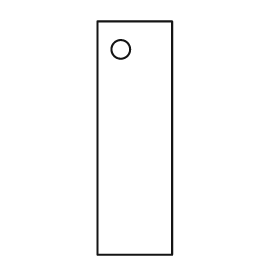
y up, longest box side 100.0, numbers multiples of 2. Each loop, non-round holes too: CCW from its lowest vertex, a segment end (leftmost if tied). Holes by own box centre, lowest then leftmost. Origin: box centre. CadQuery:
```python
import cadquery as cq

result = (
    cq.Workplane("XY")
    .moveTo(-16.0, -50.0)
    .lineTo(16.0, -50.0)
    .lineTo(16.0, 50.0)
    .lineTo(-16.0, 50.0)
    .close()
    .moveTo(-6.0, 38.0)
    .circle(4.0)
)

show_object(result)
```